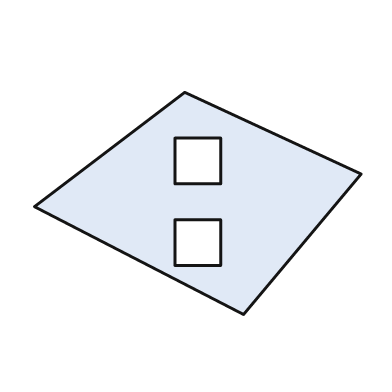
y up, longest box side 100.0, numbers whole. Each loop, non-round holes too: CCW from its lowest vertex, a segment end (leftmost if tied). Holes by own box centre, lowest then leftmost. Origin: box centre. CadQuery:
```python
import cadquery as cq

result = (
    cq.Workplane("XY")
    .moveTo(14.0, -34.0)
    .lineTo(50.0, 9.0)
    .lineTo(-4.0, 34.0)
    .lineTo(-50.0, -1.0)
    .close()
    .moveTo(-7.0, -19.0)
    .lineTo(7.0, -19.0)
    .lineTo(7.0, -5.0)
    .lineTo(-7.0, -5.0)
    .close()
    .moveTo(-7.0, 6.0)
    .lineTo(7.0, 6.0)
    .lineTo(7.0, 20.0)
    .lineTo(-7.0, 20.0)
    .close()
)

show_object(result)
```